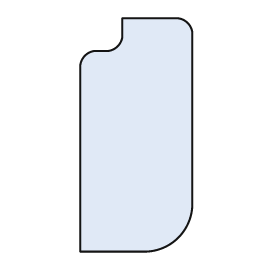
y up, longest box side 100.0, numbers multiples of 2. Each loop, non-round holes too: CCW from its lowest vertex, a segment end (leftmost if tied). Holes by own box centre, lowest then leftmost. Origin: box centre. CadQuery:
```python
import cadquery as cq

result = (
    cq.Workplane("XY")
    .moveTo(-24.0, -50.0)
    .lineTo(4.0, -50.0)
    .threePointArc((18.0, -44.0), (24.0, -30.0))
    .lineTo(24.0, 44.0)
    .threePointArc((22.0, 48.0), (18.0, 50.0))
    .lineTo(-6.0, 50.0)
    .lineTo(-6.0, 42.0)
    .threePointArc((-8.0, 38.0), (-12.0, 36.0))
    .lineTo(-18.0, 36.0)
    .threePointArc((-22.0, 34.0), (-24.0, 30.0))
    .close()
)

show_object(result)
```